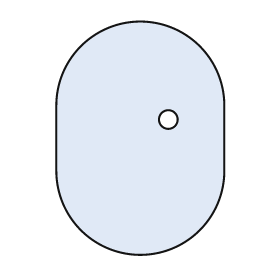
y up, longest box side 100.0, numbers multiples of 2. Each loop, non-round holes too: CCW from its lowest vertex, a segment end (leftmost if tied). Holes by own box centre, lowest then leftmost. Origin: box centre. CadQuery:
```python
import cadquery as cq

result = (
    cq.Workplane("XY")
    .moveTo(-36.0, -14.0)
    .threePointArc((0.0, -50.0), (36.0, -14.0))
    .lineTo(36.0, 14.0)
    .threePointArc((0.0, 50.0), (-36.0, 14.0))
    .close()
    .moveTo(12.0, 8.0)
    .circle(4.0)
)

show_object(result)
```